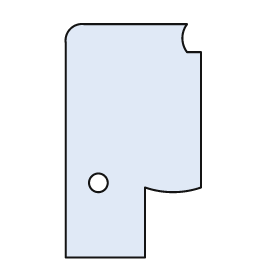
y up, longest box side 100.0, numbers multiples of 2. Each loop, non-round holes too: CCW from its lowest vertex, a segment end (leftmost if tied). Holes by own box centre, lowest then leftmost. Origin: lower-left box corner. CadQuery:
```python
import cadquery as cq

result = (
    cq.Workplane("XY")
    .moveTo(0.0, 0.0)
    .lineTo(34.0, 0.0)
    .lineTo(34.0, 30.0)
    .threePointArc((46.0, 28.0), (58.0, 30.0))
    .lineTo(58.0, 88.0)
    .lineTo(52.0, 88.0)
    .threePointArc((50.0, 94.0), (52.0, 100.0))
    .lineTo(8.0, 100.0)
    .threePointArc((2.0, 98.0), (0.0, 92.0))
    .close()
    .moveTo(14.0, 32.0)
    .circle(4.0)
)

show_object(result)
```